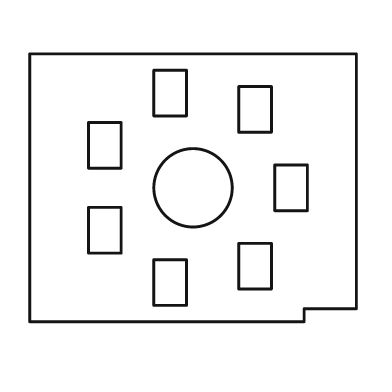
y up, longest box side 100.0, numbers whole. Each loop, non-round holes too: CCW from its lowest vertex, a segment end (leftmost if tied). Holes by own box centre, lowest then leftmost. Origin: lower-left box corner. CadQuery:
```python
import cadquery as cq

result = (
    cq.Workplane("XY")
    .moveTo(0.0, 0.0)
    .lineTo(84.0, 0.0)
    .lineTo(84.0, 4.0)
    .lineTo(100.0, 4.0)
    .lineTo(100.0, 82.0)
    .lineTo(0.0, 82.0)
    .close()
    .moveTo(38.0, 5.0)
    .lineTo(48.0, 5.0)
    .lineTo(48.0, 19.0)
    .lineTo(38.0, 19.0)
    .close()
    .moveTo(64.0, 10.0)
    .lineTo(74.0, 10.0)
    .lineTo(74.0, 24.0)
    .lineTo(64.0, 24.0)
    .close()
    .moveTo(18.0, 21.0)
    .lineTo(28.0, 21.0)
    .lineTo(28.0, 35.0)
    .lineTo(18.0, 35.0)
    .close()
    .moveTo(50.0, 41.0)
    .circle(12.0)
    .moveTo(75.0, 34.0)
    .lineTo(85.0, 34.0)
    .lineTo(85.0, 48.0)
    .lineTo(75.0, 48.0)
    .close()
    .moveTo(18.0, 47.0)
    .lineTo(28.0, 47.0)
    .lineTo(28.0, 61.0)
    .lineTo(18.0, 61.0)
    .close()
    .moveTo(64.0, 58.0)
    .lineTo(74.0, 58.0)
    .lineTo(74.0, 72.0)
    .lineTo(64.0, 72.0)
    .close()
    .moveTo(38.0, 63.0)
    .lineTo(48.0, 63.0)
    .lineTo(48.0, 77.0)
    .lineTo(38.0, 77.0)
    .close()
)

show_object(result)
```